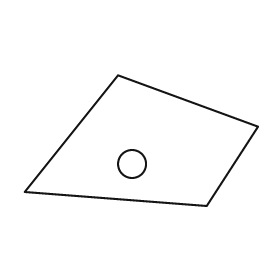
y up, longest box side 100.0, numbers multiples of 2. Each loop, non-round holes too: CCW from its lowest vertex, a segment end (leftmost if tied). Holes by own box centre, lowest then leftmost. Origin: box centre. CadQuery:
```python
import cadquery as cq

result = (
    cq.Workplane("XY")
    .moveTo(28.0, -28.0)
    .lineTo(50.0, 6.0)
    .lineTo(-10.0, 28.0)
    .lineTo(-50.0, -22.0)
    .close()
    .moveTo(-4.0, -10.0)
    .circle(6.0)
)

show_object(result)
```